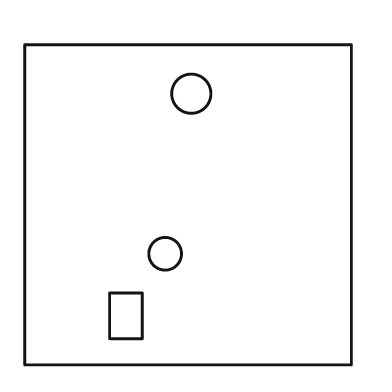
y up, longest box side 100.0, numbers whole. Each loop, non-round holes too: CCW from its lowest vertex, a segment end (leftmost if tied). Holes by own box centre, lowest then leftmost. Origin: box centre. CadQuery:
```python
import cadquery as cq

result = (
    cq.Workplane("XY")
    .moveTo(-50.0, -49.0)
    .lineTo(50.0, -49.0)
    .lineTo(50.0, 49.0)
    .lineTo(-50.0, 49.0)
    .close()
    .moveTo(-24.0, -41.0)
    .lineTo(-14.0, -41.0)
    .lineTo(-14.0, -27.0)
    .lineTo(-24.0, -27.0)
    .close()
    .moveTo(-7.0, -15.0)
    .circle(5.0)
    .moveTo(1.0, 34.0)
    .circle(6.0)
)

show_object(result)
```